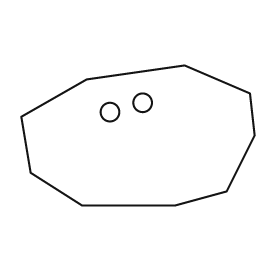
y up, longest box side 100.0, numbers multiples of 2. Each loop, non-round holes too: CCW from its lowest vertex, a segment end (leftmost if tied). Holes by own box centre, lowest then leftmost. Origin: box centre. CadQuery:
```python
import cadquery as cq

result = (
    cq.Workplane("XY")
    .moveTo(-24.0, -30.0)
    .lineTo(16.0, -30.0)
    .lineTo(38.0, -24.0)
    .lineTo(50.0, 0.0)
    .lineTo(48.0, 18.0)
    .lineTo(20.0, 30.0)
    .lineTo(-22.0, 24.0)
    .lineTo(-50.0, 8.0)
    .lineTo(-46.0, -16.0)
    .close()
    .moveTo(-12.0, 10.0)
    .circle(4.0)
    .moveTo(2.0, 14.0)
    .circle(4.0)
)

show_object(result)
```